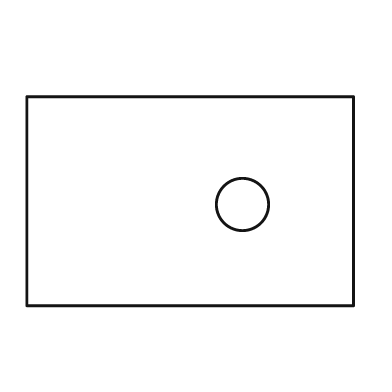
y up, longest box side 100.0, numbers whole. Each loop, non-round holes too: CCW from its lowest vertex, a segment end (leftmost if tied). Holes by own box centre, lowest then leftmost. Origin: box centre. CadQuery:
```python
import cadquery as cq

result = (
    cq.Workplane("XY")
    .moveTo(-50.0, -32.0)
    .lineTo(50.0, -32.0)
    .lineTo(50.0, 32.0)
    .lineTo(-50.0, 32.0)
    .close()
    .moveTo(16.0, -1.0)
    .circle(8.0)
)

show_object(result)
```